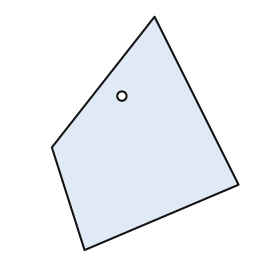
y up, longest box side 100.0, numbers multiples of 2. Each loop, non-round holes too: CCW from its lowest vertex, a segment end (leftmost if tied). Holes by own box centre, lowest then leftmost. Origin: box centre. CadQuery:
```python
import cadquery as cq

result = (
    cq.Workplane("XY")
    .moveTo(-26.0, -50.0)
    .lineTo(40.0, -22.0)
    .lineTo(4.0, 50.0)
    .lineTo(-40.0, -6.0)
    .close()
    .moveTo(-10.0, 16.0)
    .circle(2.0)
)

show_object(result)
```